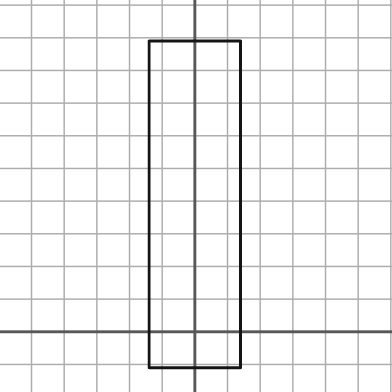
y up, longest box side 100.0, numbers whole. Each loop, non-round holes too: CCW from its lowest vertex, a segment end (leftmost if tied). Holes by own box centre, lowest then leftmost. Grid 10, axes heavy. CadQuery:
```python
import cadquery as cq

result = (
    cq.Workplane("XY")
    .moveTo(-14.0, -11.0)
    .lineTo(14.0, -11.0)
    .lineTo(14.0, 89.0)
    .lineTo(-14.0, 89.0)
    .close()
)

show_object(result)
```